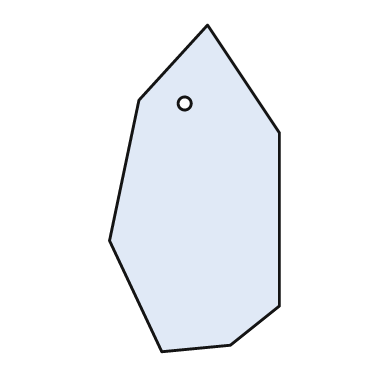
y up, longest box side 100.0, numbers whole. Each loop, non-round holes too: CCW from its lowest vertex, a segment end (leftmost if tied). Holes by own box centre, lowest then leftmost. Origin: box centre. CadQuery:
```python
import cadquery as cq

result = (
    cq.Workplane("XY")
    .moveTo(-10.0, -50.0)
    .lineTo(11.0, -48.0)
    .lineTo(26.0, -36.0)
    .lineTo(26.0, 17.0)
    .lineTo(4.0, 50.0)
    .lineTo(-17.0, 27.0)
    .lineTo(-26.0, -16.0)
    .close()
    .moveTo(-3.0, 26.0)
    .circle(2.0)
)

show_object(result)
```